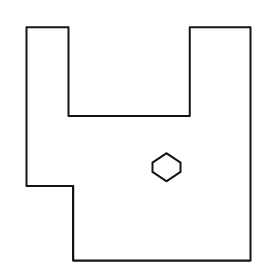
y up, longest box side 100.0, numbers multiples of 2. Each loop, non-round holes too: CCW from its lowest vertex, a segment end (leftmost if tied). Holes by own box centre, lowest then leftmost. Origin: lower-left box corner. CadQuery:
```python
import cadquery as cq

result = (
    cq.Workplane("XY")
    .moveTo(20.0, 0.0)
    .lineTo(96.0, 0.0)
    .lineTo(96.0, 100.0)
    .lineTo(70.0, 100.0)
    .lineTo(70.0, 62.0)
    .lineTo(18.0, 62.0)
    .lineTo(18.0, 100.0)
    .lineTo(0.0, 100.0)
    .lineTo(0.0, 32.0)
    .lineTo(20.0, 32.0)
    .close()
    .moveTo(60.0, 34.0)
    .lineTo(66.0, 38.0)
    .lineTo(66.0, 42.0)
    .lineTo(60.0, 46.0)
    .lineTo(54.0, 42.0)
    .lineTo(54.0, 38.0)
    .close()
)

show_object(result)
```